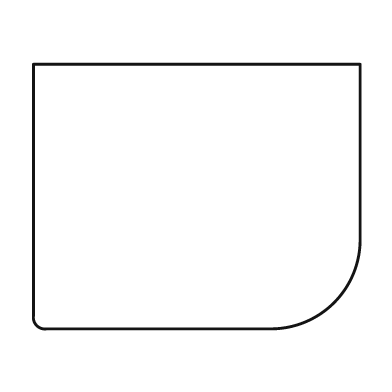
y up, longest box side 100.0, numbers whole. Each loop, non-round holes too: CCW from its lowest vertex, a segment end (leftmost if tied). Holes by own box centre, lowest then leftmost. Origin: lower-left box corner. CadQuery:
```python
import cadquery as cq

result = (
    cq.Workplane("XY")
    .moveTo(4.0, 0.0)
    .lineTo(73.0, 0.0)
    .threePointArc((92.0, 8.0), (100.0, 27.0))
    .lineTo(100.0, 81.0)
    .lineTo(0.0, 81.0)
    .lineTo(0.0, 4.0)
    .threePointArc((1.0, 1.0), (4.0, 0.0))
    .close()
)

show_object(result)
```